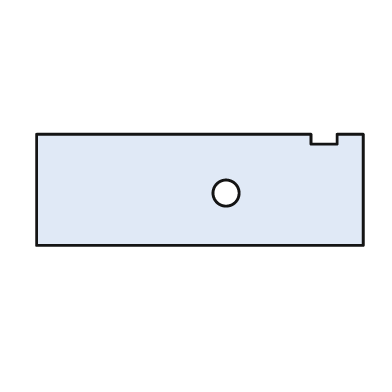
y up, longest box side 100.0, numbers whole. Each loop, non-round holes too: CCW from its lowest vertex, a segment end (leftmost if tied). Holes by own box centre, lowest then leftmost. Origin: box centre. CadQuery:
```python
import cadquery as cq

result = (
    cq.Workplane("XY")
    .moveTo(-50.0, -17.0)
    .lineTo(50.0, -17.0)
    .lineTo(50.0, 17.0)
    .lineTo(42.0, 17.0)
    .lineTo(42.0, 14.0)
    .lineTo(34.0, 14.0)
    .lineTo(34.0, 17.0)
    .lineTo(-50.0, 17.0)
    .close()
    .moveTo(8.0, -1.0)
    .circle(4.0)
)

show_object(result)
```